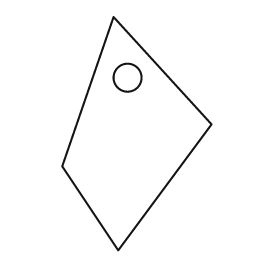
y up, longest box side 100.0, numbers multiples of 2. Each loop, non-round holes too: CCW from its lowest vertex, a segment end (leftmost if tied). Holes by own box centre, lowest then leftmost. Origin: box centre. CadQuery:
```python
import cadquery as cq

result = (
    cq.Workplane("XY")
    .moveTo(-8.0, -50.0)
    .lineTo(32.0, 4.0)
    .lineTo(-10.0, 50.0)
    .lineTo(-32.0, -14.0)
    .close()
    .moveTo(-4.0, 24.0)
    .circle(6.0)
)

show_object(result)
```